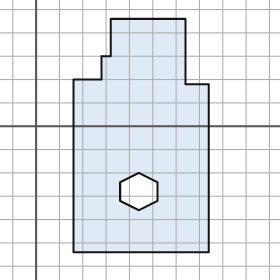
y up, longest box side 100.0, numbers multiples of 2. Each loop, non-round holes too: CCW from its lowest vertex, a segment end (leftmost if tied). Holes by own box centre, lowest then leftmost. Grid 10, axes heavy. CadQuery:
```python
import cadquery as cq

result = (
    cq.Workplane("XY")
    .moveTo(16.0, -54.0)
    .lineTo(74.0, -54.0)
    .lineTo(74.0, 18.0)
    .lineTo(64.0, 18.0)
    .lineTo(64.0, 46.0)
    .lineTo(32.0, 46.0)
    .lineTo(32.0, 30.0)
    .lineTo(28.0, 30.0)
    .lineTo(28.0, 20.0)
    .lineTo(16.0, 20.0)
    .close()
    .moveTo(44.0, -36.0)
    .lineTo(52.0, -32.0)
    .lineTo(52.0, -24.0)
    .lineTo(44.0, -20.0)
    .lineTo(36.0, -24.0)
    .lineTo(36.0, -32.0)
    .close()
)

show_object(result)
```